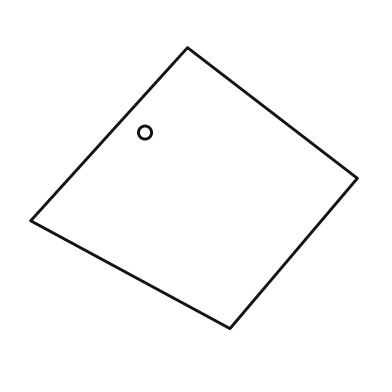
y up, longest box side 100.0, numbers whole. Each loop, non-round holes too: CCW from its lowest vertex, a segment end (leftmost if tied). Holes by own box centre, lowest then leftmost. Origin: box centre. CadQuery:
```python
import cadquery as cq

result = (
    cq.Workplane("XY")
    .moveTo(11.0, -43.0)
    .lineTo(50.0, 3.0)
    .lineTo(-2.0, 43.0)
    .lineTo(-50.0, -10.0)
    .close()
    .moveTo(-15.0, 17.0)
    .circle(2.0)
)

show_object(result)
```